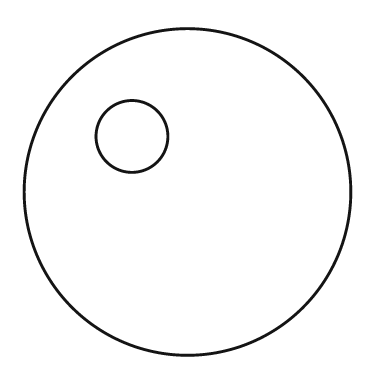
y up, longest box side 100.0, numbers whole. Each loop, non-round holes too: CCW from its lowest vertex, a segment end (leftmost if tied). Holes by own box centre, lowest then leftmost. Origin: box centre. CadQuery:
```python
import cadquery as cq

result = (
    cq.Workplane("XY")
    .moveTo(0.0, 0.0)
    .circle(50.0)
    .moveTo(-17.0, 17.0)
    .circle(11.0)
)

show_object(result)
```